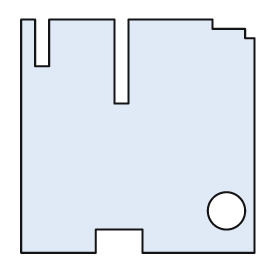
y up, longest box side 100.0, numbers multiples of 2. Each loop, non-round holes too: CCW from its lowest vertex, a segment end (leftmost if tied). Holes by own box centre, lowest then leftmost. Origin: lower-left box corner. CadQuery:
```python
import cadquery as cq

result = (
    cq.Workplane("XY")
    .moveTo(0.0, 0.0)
    .lineTo(32.0, 0.0)
    .lineTo(32.0, 10.0)
    .lineTo(52.0, 10.0)
    .lineTo(52.0, 0.0)
    .lineTo(100.0, 0.0)
    .lineTo(100.0, 92.0)
    .lineTo(96.0, 92.0)
    .lineTo(96.0, 96.0)
    .lineTo(82.0, 96.0)
    .lineTo(82.0, 100.0)
    .lineTo(46.0, 100.0)
    .lineTo(46.0, 64.0)
    .lineTo(40.0, 64.0)
    .lineTo(40.0, 100.0)
    .lineTo(12.0, 100.0)
    .lineTo(12.0, 80.0)
    .lineTo(6.0, 80.0)
    .lineTo(6.0, 100.0)
    .lineTo(0.0, 100.0)
    .close()
    .moveTo(88.0, 18.0)
    .circle(8.0)
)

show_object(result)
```